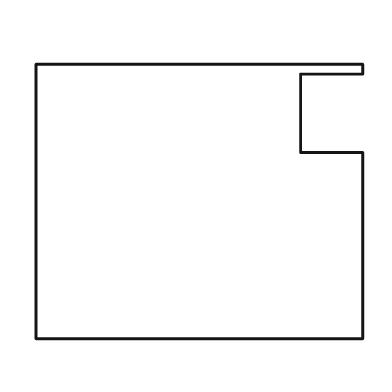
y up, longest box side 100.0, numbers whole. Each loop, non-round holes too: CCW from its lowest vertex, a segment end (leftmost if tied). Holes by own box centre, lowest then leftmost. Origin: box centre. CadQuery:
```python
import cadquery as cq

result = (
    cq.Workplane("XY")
    .moveTo(-50.0, -42.0)
    .lineTo(50.0, -42.0)
    .lineTo(50.0, 15.0)
    .lineTo(31.0, 15.0)
    .lineTo(31.0, 39.0)
    .lineTo(50.0, 39.0)
    .lineTo(50.0, 42.0)
    .lineTo(-50.0, 42.0)
    .close()
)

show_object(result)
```